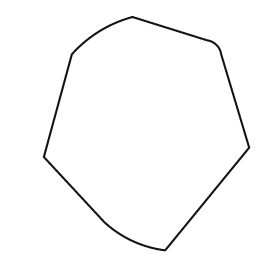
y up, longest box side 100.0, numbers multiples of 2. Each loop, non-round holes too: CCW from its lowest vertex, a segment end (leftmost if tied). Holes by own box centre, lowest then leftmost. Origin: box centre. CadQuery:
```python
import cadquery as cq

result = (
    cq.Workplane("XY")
    .moveTo(8.0, -50.0)
    .lineTo(44.0, -6.0)
    .lineTo(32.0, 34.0)
    .threePointArc((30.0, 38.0), (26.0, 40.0))
    .lineTo(-6.0, 50.0)
    .threePointArc((-20.0, 44.0), (-32.0, 34.0))
    .lineTo(-44.0, -10.0)
    .lineTo(-18.0, -38.0)
    .threePointArc((-6.0, -46.0), (8.0, -50.0))
    .close()
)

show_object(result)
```